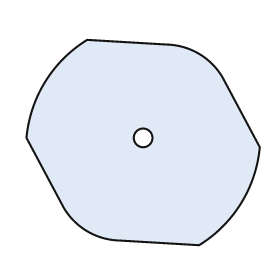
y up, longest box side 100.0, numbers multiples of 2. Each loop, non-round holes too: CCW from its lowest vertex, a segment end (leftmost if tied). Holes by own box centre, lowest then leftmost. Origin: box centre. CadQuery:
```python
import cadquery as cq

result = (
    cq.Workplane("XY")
    .moveTo(24.0, -44.0)
    .threePointArc((42.0, -26.0), (50.0, -2.0))
    .lineTo(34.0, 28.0)
    .threePointArc((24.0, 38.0), (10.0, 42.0))
    .lineTo(-24.0, 44.0)
    .threePointArc((-42.0, 26.0), (-50.0, 2.0))
    .lineTo(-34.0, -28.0)
    .threePointArc((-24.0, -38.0), (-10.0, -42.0))
    .close()
    .moveTo(0.0, 2.0)
    .circle(4.0)
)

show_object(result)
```